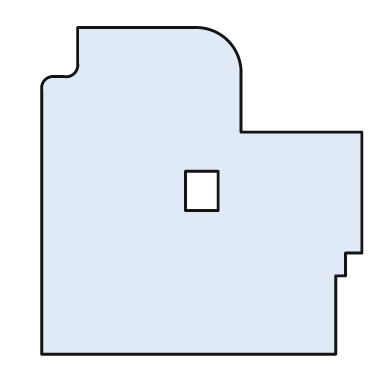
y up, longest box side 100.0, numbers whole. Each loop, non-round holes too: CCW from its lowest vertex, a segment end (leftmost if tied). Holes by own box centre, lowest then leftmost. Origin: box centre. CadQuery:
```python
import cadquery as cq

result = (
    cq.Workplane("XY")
    .moveTo(-49.0, -50.0)
    .lineTo(41.0, -50.0)
    .lineTo(41.0, -26.0)
    .lineTo(44.0, -26.0)
    .lineTo(44.0, -19.0)
    .lineTo(49.0, -19.0)
    .lineTo(49.0, 18.0)
    .lineTo(12.0, 18.0)
    .lineTo(12.0, 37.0)
    .threePointArc((8.0, 46.0), (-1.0, 50.0))
    .lineTo(-38.0, 50.0)
    .lineTo(-38.0, 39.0)
    .threePointArc((-39.0, 36.0), (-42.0, 35.0))
    .lineTo(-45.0, 35.0)
    .threePointArc((-48.0, 34.0), (-49.0, 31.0))
    .close()
    .moveTo(-5.0, -6.0)
    .lineTo(5.0, -6.0)
    .lineTo(5.0, 6.0)
    .lineTo(-5.0, 6.0)
    .close()
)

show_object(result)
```